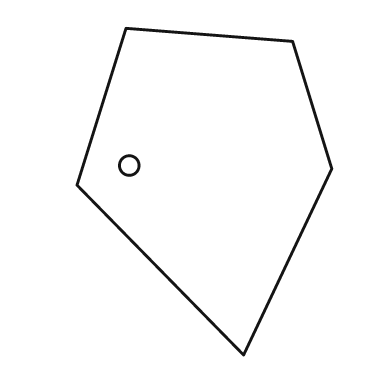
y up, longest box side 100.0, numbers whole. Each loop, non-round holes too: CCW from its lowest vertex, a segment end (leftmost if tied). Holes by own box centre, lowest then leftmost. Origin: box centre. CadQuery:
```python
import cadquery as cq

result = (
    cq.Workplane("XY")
    .moveTo(12.0, -50.0)
    .lineTo(39.0, 7.0)
    .lineTo(27.0, 46.0)
    .lineTo(-24.0, 50.0)
    .lineTo(-39.0, 2.0)
    .close()
    .moveTo(-23.0, 8.0)
    .circle(3.0)
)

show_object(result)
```